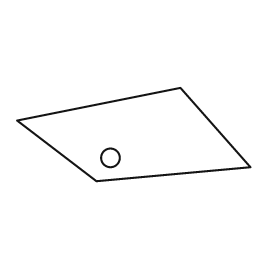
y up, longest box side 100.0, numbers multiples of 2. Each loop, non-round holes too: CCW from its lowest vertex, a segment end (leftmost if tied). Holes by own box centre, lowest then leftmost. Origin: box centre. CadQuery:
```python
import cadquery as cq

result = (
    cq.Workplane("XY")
    .moveTo(-16.0, -20.0)
    .lineTo(50.0, -14.0)
    .lineTo(20.0, 20.0)
    .lineTo(-50.0, 6.0)
    .close()
    .moveTo(-10.0, -10.0)
    .circle(4.0)
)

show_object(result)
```